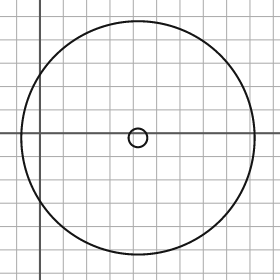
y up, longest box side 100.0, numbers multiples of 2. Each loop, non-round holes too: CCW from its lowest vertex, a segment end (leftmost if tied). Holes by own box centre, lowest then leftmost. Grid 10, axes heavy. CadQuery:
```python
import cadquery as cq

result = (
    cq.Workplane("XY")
    .moveTo(42.0, -2.0)
    .circle(50.0)
    .moveTo(42.0, -2.0)
    .circle(4.0)
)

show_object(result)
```